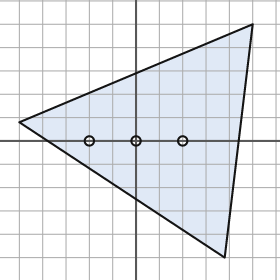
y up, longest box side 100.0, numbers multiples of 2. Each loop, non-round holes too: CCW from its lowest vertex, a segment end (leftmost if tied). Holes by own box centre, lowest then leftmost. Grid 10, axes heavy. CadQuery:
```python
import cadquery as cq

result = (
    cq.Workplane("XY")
    .moveTo(38.0, -50.0)
    .lineTo(50.0, 50.0)
    .lineTo(-50.0, 8.0)
    .close()
    .moveTo(-20.0, 0.0)
    .circle(2.0)
    .moveTo(0.0, 0.0)
    .circle(2.0)
    .moveTo(20.0, 0.0)
    .circle(2.0)
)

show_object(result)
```